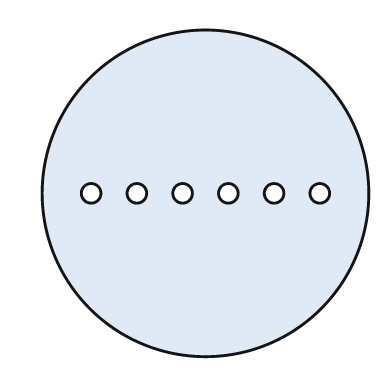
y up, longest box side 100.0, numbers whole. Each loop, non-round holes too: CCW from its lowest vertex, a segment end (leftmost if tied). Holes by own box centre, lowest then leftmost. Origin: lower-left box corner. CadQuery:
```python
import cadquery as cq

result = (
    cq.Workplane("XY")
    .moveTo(50.0, 50.0)
    .circle(50.0)
    .moveTo(15.0, 50.0)
    .circle(3.0)
    .moveTo(29.0, 50.0)
    .circle(3.0)
    .moveTo(43.0, 50.0)
    .circle(3.0)
    .moveTo(57.0, 50.0)
    .circle(3.0)
    .moveTo(71.0, 50.0)
    .circle(3.0)
    .moveTo(85.0, 50.0)
    .circle(3.0)
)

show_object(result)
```